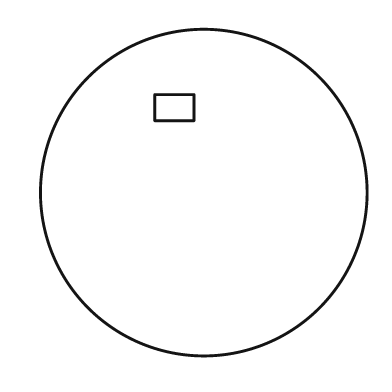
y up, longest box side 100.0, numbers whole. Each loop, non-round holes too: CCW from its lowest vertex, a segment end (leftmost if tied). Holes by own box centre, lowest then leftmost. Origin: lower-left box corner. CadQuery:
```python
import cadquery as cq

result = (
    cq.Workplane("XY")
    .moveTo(50.0, 50.0)
    .circle(50.0)
    .moveTo(35.0, 72.0)
    .lineTo(47.0, 72.0)
    .lineTo(47.0, 80.0)
    .lineTo(35.0, 80.0)
    .close()
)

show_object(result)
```